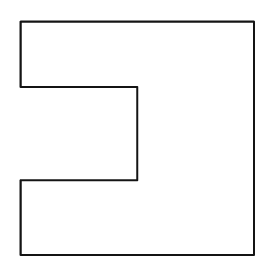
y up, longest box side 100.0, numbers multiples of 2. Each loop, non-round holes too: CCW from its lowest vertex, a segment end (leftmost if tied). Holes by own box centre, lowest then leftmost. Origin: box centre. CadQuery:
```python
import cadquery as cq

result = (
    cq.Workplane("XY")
    .moveTo(-50.0, -50.0)
    .lineTo(50.0, -50.0)
    .lineTo(50.0, 50.0)
    .lineTo(-50.0, 50.0)
    .lineTo(-50.0, 22.0)
    .lineTo(0.0, 22.0)
    .lineTo(0.0, -18.0)
    .lineTo(-50.0, -18.0)
    .close()
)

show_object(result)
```